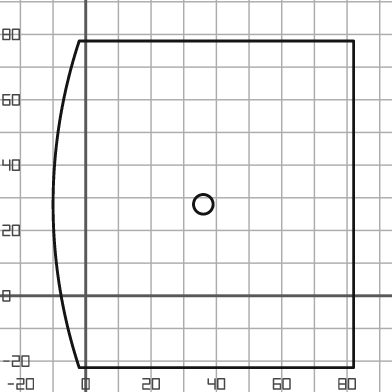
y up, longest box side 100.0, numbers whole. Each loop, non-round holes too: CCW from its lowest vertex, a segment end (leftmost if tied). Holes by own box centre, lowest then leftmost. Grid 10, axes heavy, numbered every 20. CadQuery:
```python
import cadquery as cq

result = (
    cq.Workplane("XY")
    .moveTo(-2.0, -22.0)
    .lineTo(82.0, -22.0)
    .lineTo(82.0, 78.0)
    .lineTo(-2.0, 78.0)
    .threePointArc((-10.0, 28.0), (-2.0, -22.0))
    .close()
    .moveTo(36.0, 28.0)
    .circle(3.0)
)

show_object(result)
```